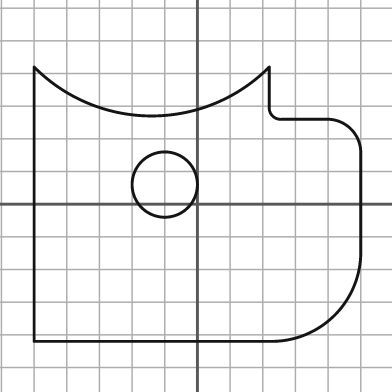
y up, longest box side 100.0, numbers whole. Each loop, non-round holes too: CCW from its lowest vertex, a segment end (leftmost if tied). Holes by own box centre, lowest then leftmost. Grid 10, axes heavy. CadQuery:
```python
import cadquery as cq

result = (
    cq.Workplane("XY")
    .moveTo(-50.0, -42.0)
    .lineTo(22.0, -42.0)
    .threePointArc((42.0, -34.0), (50.0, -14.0))
    .lineTo(50.0, 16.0)
    .threePointArc((47.0, 23.0), (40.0, 26.0))
    .lineTo(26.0, 26.0)
    .threePointArc((23.0, 27.0), (22.0, 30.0))
    .lineTo(22.0, 42.0)
    .threePointArc((-14.0, 27.0), (-50.0, 42.0))
    .close()
    .moveTo(-10.0, 6.0)
    .circle(10.0)
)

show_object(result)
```